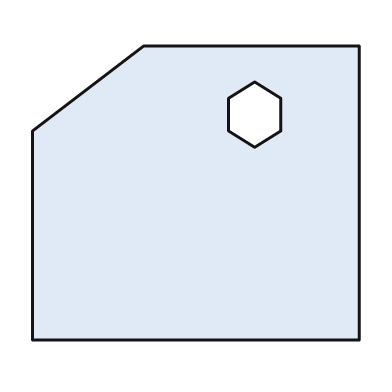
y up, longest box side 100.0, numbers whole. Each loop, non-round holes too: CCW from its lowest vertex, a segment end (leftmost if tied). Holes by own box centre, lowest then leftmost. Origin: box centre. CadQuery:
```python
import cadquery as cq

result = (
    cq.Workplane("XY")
    .moveTo(-50.0, -45.0)
    .lineTo(50.0, -45.0)
    .lineTo(50.0, 45.0)
    .lineTo(-16.0, 45.0)
    .lineTo(-50.0, 19.0)
    .close()
    .moveTo(18.0, 14.0)
    .lineTo(26.0, 19.0)
    .lineTo(26.0, 29.0)
    .lineTo(18.0, 34.0)
    .lineTo(10.0, 29.0)
    .lineTo(10.0, 19.0)
    .close()
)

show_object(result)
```